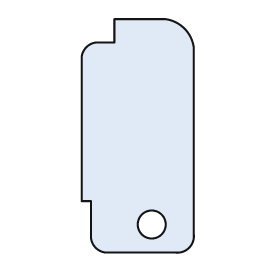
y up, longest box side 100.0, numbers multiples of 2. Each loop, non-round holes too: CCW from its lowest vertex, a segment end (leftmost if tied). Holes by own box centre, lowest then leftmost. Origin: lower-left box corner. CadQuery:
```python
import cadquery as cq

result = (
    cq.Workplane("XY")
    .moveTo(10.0, 0.0)
    .lineTo(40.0, 0.0)
    .threePointArc((46.0, 2.0), (48.0, 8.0))
    .lineTo(48.0, 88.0)
    .threePointArc((44.0, 96.0), (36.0, 100.0))
    .lineTo(14.0, 100.0)
    .lineTo(14.0, 90.0)
    .lineTo(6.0, 90.0)
    .threePointArc((2.0, 88.0), (0.0, 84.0))
    .lineTo(0.0, 22.0)
    .lineTo(4.0, 22.0)
    .lineTo(4.0, 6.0)
    .threePointArc((6.0, 2.0), (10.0, 0.0))
    .close()
    .moveTo(30.0, 12.0)
    .circle(6.0)
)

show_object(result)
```